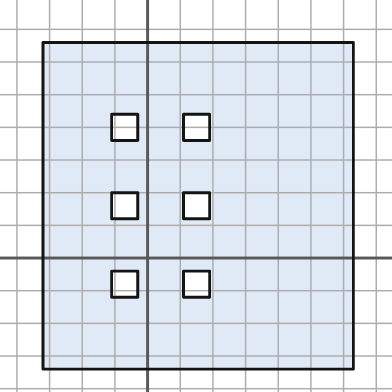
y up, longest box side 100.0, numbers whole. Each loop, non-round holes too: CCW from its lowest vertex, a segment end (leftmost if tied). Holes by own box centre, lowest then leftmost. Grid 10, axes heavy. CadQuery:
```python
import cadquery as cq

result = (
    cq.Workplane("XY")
    .moveTo(-32.0, -34.0)
    .lineTo(63.0, -34.0)
    .lineTo(63.0, 66.0)
    .lineTo(-32.0, 66.0)
    .close()
    .moveTo(-11.0, -12.0)
    .lineTo(-3.0, -12.0)
    .lineTo(-3.0, -4.0)
    .lineTo(-11.0, -4.0)
    .close()
    .moveTo(11.0, -12.0)
    .lineTo(19.0, -12.0)
    .lineTo(19.0, -4.0)
    .lineTo(11.0, -4.0)
    .close()
    .moveTo(-11.0, 12.0)
    .lineTo(-3.0, 12.0)
    .lineTo(-3.0, 20.0)
    .lineTo(-11.0, 20.0)
    .close()
    .moveTo(11.0, 12.0)
    .lineTo(19.0, 12.0)
    .lineTo(19.0, 20.0)
    .lineTo(11.0, 20.0)
    .close()
    .moveTo(-11.0, 36.0)
    .lineTo(-3.0, 36.0)
    .lineTo(-3.0, 44.0)
    .lineTo(-11.0, 44.0)
    .close()
    .moveTo(11.0, 36.0)
    .lineTo(19.0, 36.0)
    .lineTo(19.0, 44.0)
    .lineTo(11.0, 44.0)
    .close()
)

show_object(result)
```